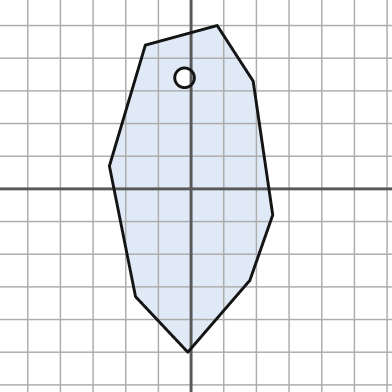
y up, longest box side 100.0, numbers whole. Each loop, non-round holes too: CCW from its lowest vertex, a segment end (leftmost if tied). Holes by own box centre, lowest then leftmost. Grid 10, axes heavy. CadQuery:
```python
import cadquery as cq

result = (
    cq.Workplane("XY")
    .moveTo(-1.0, -50.0)
    .lineTo(18.0, -28.0)
    .lineTo(25.0, -8.0)
    .lineTo(19.0, 33.0)
    .lineTo(8.0, 50.0)
    .lineTo(-14.0, 44.0)
    .lineTo(-25.0, 7.0)
    .lineTo(-17.0, -33.0)
    .close()
    .moveTo(-2.0, 34.0)
    .circle(3.0)
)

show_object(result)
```